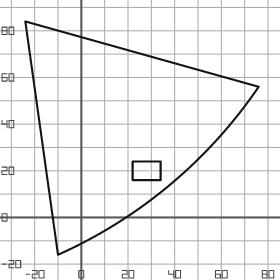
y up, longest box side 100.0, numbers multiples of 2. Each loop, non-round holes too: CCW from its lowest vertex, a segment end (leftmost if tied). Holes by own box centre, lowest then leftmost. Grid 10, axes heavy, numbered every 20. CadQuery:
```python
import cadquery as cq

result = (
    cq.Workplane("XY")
    .moveTo(-10.0, -16.0)
    .threePointArc((38.0, 14.0), (76.0, 56.0))
    .lineTo(-24.0, 84.0)
    .close()
    .moveTo(22.0, 16.0)
    .lineTo(34.0, 16.0)
    .lineTo(34.0, 24.0)
    .lineTo(22.0, 24.0)
    .close()
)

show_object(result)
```